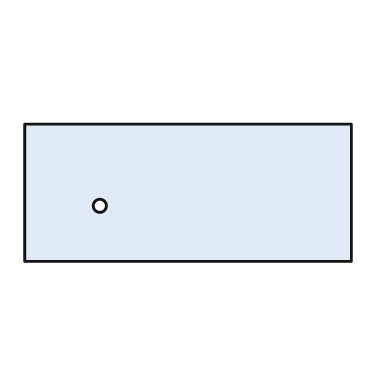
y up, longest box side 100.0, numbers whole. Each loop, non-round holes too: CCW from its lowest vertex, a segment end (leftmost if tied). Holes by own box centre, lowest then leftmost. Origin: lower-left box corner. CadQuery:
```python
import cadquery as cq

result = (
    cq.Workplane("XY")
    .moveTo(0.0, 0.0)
    .lineTo(100.0, 0.0)
    .lineTo(100.0, 42.0)
    .lineTo(0.0, 42.0)
    .close()
    .moveTo(23.0, 17.0)
    .circle(2.0)
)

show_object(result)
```